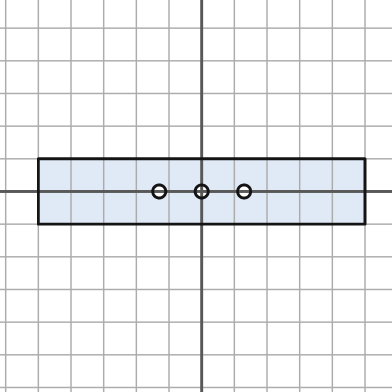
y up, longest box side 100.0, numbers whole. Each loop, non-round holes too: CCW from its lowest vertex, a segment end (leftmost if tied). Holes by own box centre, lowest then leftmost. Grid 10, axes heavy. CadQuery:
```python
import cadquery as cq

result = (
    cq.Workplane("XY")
    .moveTo(-50.0, -10.0)
    .lineTo(50.0, -10.0)
    .lineTo(50.0, 10.0)
    .lineTo(-50.0, 10.0)
    .close()
    .moveTo(-13.0, 0.0)
    .circle(2.0)
    .moveTo(0.0, 0.0)
    .circle(2.0)
    .moveTo(13.0, 0.0)
    .circle(2.0)
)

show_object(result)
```